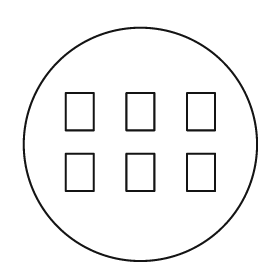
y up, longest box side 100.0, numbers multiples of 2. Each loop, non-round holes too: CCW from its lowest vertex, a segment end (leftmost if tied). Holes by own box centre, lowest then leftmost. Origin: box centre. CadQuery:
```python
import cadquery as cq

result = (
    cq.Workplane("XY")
    .moveTo(0.0, 0.0)
    .circle(50.0)
    .moveTo(-32.0, -20.0)
    .lineTo(-20.0, -20.0)
    .lineTo(-20.0, -4.0)
    .lineTo(-32.0, -4.0)
    .close()
    .moveTo(-6.0, -20.0)
    .lineTo(6.0, -20.0)
    .lineTo(6.0, -4.0)
    .lineTo(-6.0, -4.0)
    .close()
    .moveTo(20.0, -20.0)
    .lineTo(32.0, -20.0)
    .lineTo(32.0, -4.0)
    .lineTo(20.0, -4.0)
    .close()
    .moveTo(-32.0, 6.0)
    .lineTo(-20.0, 6.0)
    .lineTo(-20.0, 22.0)
    .lineTo(-32.0, 22.0)
    .close()
    .moveTo(-6.0, 6.0)
    .lineTo(6.0, 6.0)
    .lineTo(6.0, 22.0)
    .lineTo(-6.0, 22.0)
    .close()
    .moveTo(20.0, 6.0)
    .lineTo(32.0, 6.0)
    .lineTo(32.0, 22.0)
    .lineTo(20.0, 22.0)
    .close()
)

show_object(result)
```